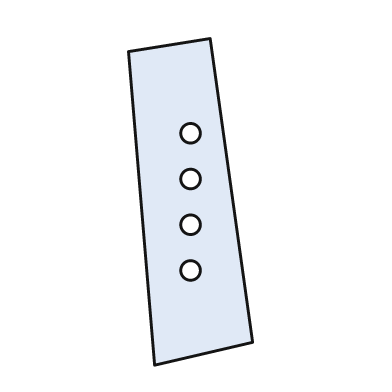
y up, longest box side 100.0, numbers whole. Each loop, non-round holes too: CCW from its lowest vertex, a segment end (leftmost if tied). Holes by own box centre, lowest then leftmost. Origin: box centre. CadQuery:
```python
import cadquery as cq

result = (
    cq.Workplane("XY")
    .moveTo(-11.0, -50.0)
    .lineTo(19.0, -43.0)
    .lineTo(6.0, 50.0)
    .lineTo(-19.0, 46.0)
    .close()
    .moveTo(0.0, -21.0)
    .circle(3.0)
    .moveTo(0.0, -7.0)
    .circle(3.0)
    .moveTo(0.0, 7.0)
    .circle(3.0)
    .moveTo(0.0, 21.0)
    .circle(3.0)
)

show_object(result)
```